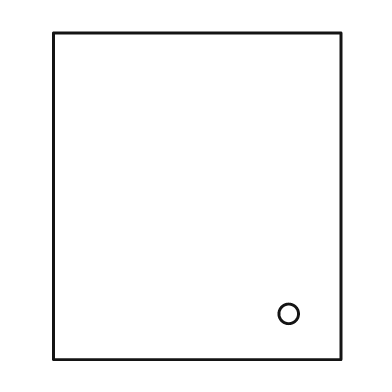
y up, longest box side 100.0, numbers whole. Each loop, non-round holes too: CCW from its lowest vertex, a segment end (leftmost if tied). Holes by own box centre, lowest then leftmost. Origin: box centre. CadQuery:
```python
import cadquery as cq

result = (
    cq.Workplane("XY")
    .moveTo(-44.0, -50.0)
    .lineTo(44.0, -50.0)
    .lineTo(44.0, 50.0)
    .lineTo(-44.0, 50.0)
    .close()
    .moveTo(28.0, -36.0)
    .circle(3.0)
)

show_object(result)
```